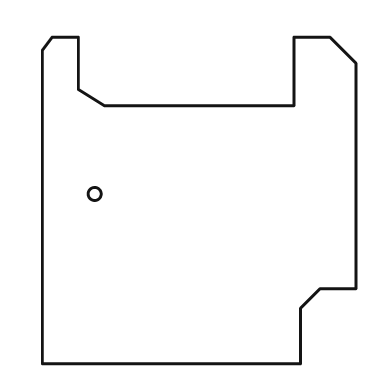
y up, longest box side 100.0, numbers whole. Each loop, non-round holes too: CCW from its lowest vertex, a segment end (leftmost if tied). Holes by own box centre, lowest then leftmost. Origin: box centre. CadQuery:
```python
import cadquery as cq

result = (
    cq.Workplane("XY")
    .moveTo(-48.0, -50.0)
    .lineTo(31.0, -50.0)
    .lineTo(31.0, -33.0)
    .lineTo(37.0, -27.0)
    .lineTo(48.0, -27.0)
    .lineTo(48.0, 42.0)
    .lineTo(40.0, 50.0)
    .lineTo(29.0, 50.0)
    .lineTo(29.0, 29.0)
    .lineTo(-29.0, 29.0)
    .lineTo(-37.0, 34.0)
    .lineTo(-37.0, 50.0)
    .lineTo(-45.0, 50.0)
    .lineTo(-48.0, 46.0)
    .close()
    .moveTo(-32.0, 2.0)
    .circle(2.0)
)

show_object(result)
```